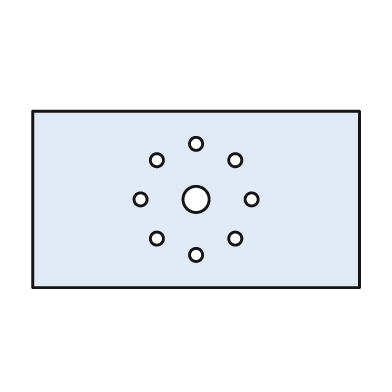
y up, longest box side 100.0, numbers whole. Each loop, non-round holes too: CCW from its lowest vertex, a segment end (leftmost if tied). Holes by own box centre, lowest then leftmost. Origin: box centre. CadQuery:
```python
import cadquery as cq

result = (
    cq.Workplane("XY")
    .moveTo(-50.0, -27.0)
    .lineTo(50.0, -27.0)
    .lineTo(50.0, 27.0)
    .lineTo(-50.0, 27.0)
    .close()
    .moveTo(0.0, -17.0)
    .circle(2.0)
    .moveTo(-12.0, -12.0)
    .circle(2.0)
    .moveTo(12.0, -12.0)
    .circle(2.0)
    .moveTo(-17.0, 0.0)
    .circle(2.0)
    .moveTo(0.0, 0.0)
    .circle(4.0)
    .moveTo(17.0, 0.0)
    .circle(2.0)
    .moveTo(-12.0, 12.0)
    .circle(2.0)
    .moveTo(12.0, 12.0)
    .circle(2.0)
    .moveTo(0.0, 17.0)
    .circle(2.0)
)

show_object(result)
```